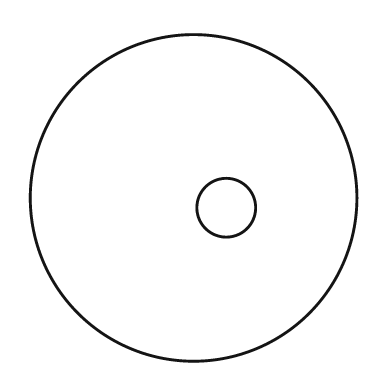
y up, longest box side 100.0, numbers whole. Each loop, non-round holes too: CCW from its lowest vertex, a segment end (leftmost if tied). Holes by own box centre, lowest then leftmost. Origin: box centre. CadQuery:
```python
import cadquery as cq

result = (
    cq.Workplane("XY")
    .moveTo(0.0, 0.0)
    .circle(50.0)
    .moveTo(10.0, -3.0)
    .circle(9.0)
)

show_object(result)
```